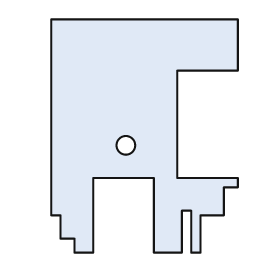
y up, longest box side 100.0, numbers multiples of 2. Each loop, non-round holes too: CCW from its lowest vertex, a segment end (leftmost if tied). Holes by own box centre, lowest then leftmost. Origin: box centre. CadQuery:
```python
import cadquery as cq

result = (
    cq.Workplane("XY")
    .moveTo(-30.0, -50.0)
    .lineTo(-22.0, -50.0)
    .lineTo(-22.0, -18.0)
    .lineTo(4.0, -18.0)
    .lineTo(4.0, -50.0)
    .lineTo(16.0, -50.0)
    .lineTo(16.0, -32.0)
    .lineTo(20.0, -32.0)
    .lineTo(20.0, -50.0)
    .lineTo(24.0, -50.0)
    .lineTo(24.0, -34.0)
    .lineTo(34.0, -34.0)
    .lineTo(34.0, -22.0)
    .lineTo(40.0, -22.0)
    .lineTo(40.0, -18.0)
    .lineTo(14.0, -18.0)
    .lineTo(14.0, 28.0)
    .lineTo(40.0, 28.0)
    .lineTo(40.0, 50.0)
    .lineTo(-40.0, 50.0)
    .lineTo(-40.0, -34.0)
    .lineTo(-36.0, -34.0)
    .lineTo(-36.0, -44.0)
    .lineTo(-30.0, -44.0)
    .close()
    .moveTo(-8.0, -4.0)
    .circle(4.0)
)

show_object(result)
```